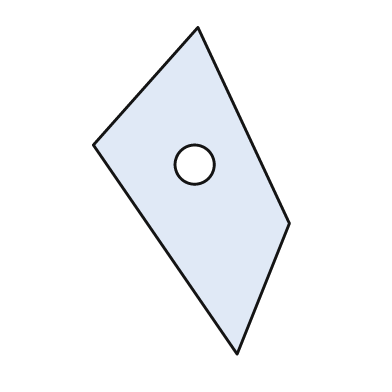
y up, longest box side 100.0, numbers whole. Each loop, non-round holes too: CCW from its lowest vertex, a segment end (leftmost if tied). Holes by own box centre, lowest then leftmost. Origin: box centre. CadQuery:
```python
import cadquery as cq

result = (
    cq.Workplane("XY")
    .moveTo(14.0, -50.0)
    .lineTo(30.0, -10.0)
    .lineTo(2.0, 50.0)
    .lineTo(-30.0, 14.0)
    .close()
    .moveTo(1.0, 8.0)
    .circle(6.0)
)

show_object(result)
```